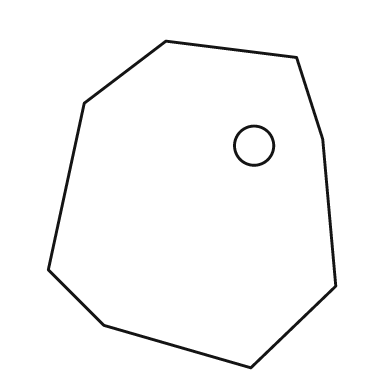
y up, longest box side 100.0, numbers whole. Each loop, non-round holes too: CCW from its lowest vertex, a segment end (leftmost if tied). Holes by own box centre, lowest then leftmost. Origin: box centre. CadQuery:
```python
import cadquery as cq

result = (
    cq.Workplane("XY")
    .moveTo(18.0, -50.0)
    .lineTo(44.0, -25.0)
    .lineTo(40.0, 20.0)
    .lineTo(32.0, 45.0)
    .lineTo(-8.0, 50.0)
    .lineTo(-33.0, 31.0)
    .lineTo(-44.0, -20.0)
    .lineTo(-27.0, -37.0)
    .close()
    .moveTo(19.0, 18.0)
    .circle(6.0)
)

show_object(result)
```